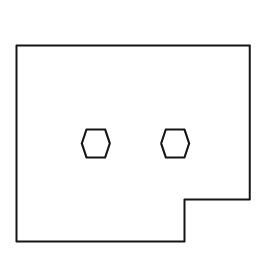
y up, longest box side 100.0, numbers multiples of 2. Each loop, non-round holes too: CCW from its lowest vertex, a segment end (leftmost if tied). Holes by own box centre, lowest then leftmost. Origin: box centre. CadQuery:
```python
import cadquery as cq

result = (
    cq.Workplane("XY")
    .moveTo(-50.0, -42.0)
    .lineTo(22.0, -42.0)
    .lineTo(22.0, -24.0)
    .lineTo(50.0, -24.0)
    .lineTo(50.0, 42.0)
    .lineTo(-50.0, 42.0)
    .close()
    .moveTo(-20.0, -6.0)
    .lineTo(-12.0, -6.0)
    .lineTo(-10.0, 0.0)
    .lineTo(-12.0, 6.0)
    .lineTo(-20.0, 6.0)
    .lineTo(-22.0, 0.0)
    .close()
    .moveTo(14.0, -6.0)
    .lineTo(22.0, -6.0)
    .lineTo(24.0, 0.0)
    .lineTo(22.0, 6.0)
    .lineTo(14.0, 6.0)
    .lineTo(12.0, 0.0)
    .close()
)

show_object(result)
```